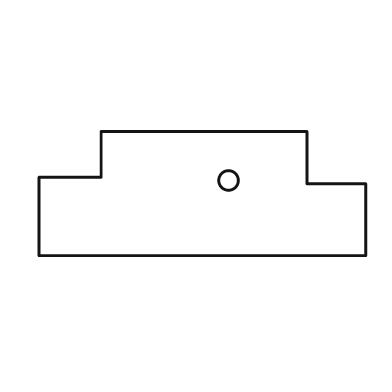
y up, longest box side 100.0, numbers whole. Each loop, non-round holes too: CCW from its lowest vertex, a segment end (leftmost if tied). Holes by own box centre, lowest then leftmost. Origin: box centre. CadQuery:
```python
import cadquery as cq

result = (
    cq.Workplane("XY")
    .moveTo(-50.0, -19.0)
    .lineTo(50.0, -19.0)
    .lineTo(50.0, 3.0)
    .lineTo(32.0, 3.0)
    .lineTo(32.0, 19.0)
    .lineTo(-31.0, 19.0)
    .lineTo(-31.0, 5.0)
    .lineTo(-50.0, 5.0)
    .close()
    .moveTo(8.0, 4.0)
    .circle(3.0)
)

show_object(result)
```